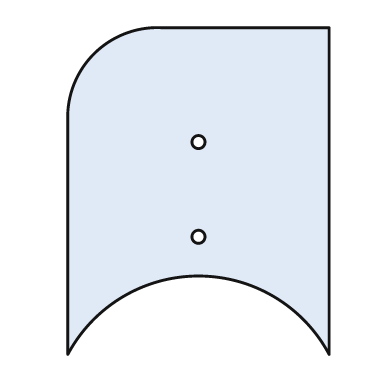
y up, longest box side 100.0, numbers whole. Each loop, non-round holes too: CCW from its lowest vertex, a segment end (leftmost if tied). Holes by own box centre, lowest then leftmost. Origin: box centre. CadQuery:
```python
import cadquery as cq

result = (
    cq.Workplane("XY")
    .moveTo(-40.0, -50.0)
    .threePointArc((0.0, -26.0), (40.0, -50.0))
    .lineTo(40.0, 50.0)
    .lineTo(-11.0, 50.0)
    .threePointArc((-32.0, 42.0), (-40.0, 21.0))
    .close()
    .moveTo(0.0, -14.0)
    .circle(2.0)
    .moveTo(0.0, 15.0)
    .circle(2.0)
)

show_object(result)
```